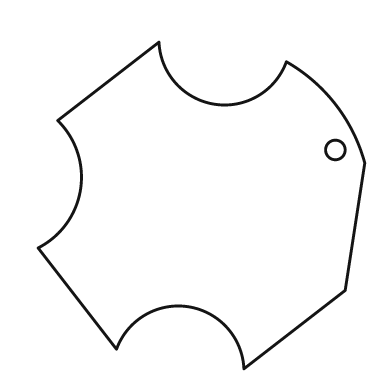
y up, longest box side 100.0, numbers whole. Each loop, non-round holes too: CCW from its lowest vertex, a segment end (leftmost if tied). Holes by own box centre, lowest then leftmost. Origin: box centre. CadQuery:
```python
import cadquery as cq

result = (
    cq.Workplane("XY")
    .moveTo(13.0, -50.0)
    .lineTo(44.0, -26.0)
    .lineTo(50.0, 13.0)
    .threePointArc((41.0, 31.0), (26.0, 44.0))
    .threePointArc((4.0, 31.0), (-13.0, 50.0))
    .lineTo(-44.0, 26.0)
    .threePointArc((-37.0, 5.0), (-50.0, -13.0))
    .lineTo(-26.0, -44.0)
    .threePointArc((-4.0, -31.0), (13.0, -50.0))
    .close()
    .moveTo(41.0, 17.0)
    .circle(3.0)
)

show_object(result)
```